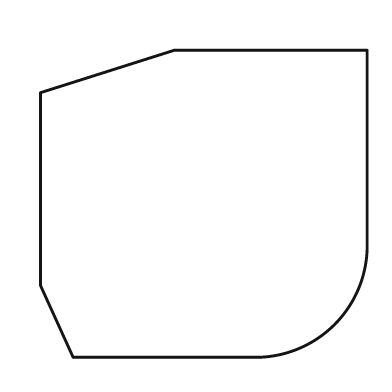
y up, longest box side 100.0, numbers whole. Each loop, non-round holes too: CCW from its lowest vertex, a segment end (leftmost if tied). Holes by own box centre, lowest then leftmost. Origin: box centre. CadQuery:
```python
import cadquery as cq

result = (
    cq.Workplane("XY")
    .moveTo(-40.0, -47.0)
    .lineTo(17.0, -47.0)
    .threePointArc((40.0, -37.0), (50.0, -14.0))
    .lineTo(50.0, 47.0)
    .lineTo(-9.0, 47.0)
    .lineTo(-50.0, 34.0)
    .lineTo(-50.0, -25.0)
    .close()
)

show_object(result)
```